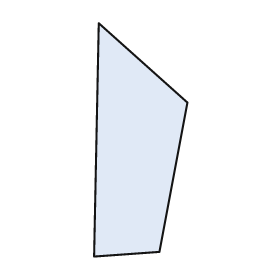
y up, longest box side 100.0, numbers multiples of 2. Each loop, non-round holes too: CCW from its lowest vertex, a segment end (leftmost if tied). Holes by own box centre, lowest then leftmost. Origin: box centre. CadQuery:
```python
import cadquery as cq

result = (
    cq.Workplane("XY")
    .moveTo(-20.0, -50.0)
    .lineTo(8.0, -48.0)
    .lineTo(20.0, 16.0)
    .lineTo(-18.0, 50.0)
    .close()
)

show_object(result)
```